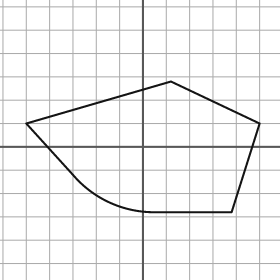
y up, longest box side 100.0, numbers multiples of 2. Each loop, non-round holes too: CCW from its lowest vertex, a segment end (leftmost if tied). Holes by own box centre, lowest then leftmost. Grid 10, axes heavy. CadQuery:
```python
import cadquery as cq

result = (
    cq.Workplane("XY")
    .moveTo(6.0, -28.0)
    .lineTo(38.0, -28.0)
    .lineTo(50.0, 10.0)
    .lineTo(12.0, 28.0)
    .lineTo(-50.0, 10.0)
    .lineTo(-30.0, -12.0)
    .threePointArc((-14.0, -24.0), (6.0, -28.0))
    .close()
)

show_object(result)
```